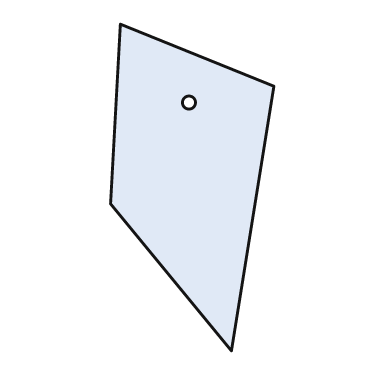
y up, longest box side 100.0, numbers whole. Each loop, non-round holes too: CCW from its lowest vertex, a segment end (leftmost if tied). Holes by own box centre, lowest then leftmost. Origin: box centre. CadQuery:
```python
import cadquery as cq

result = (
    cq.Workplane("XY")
    .moveTo(12.0, -50.0)
    .lineTo(25.0, 31.0)
    .lineTo(-22.0, 50.0)
    .lineTo(-25.0, -5.0)
    .close()
    .moveTo(-1.0, 26.0)
    .circle(2.0)
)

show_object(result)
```